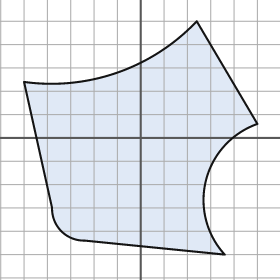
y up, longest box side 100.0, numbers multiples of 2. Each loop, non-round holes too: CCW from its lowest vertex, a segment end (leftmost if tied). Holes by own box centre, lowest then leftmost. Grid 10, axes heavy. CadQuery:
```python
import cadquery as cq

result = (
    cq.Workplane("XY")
    .moveTo(36.0, -50.0)
    .threePointArc((28.0, -18.0), (50.0, 6.0))
    .lineTo(24.0, 50.0)
    .threePointArc((-10.0, 28.0), (-50.0, 24.0))
    .lineTo(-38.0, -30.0)
    .threePointArc((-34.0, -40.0), (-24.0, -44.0))
    .close()
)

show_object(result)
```